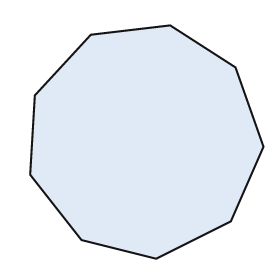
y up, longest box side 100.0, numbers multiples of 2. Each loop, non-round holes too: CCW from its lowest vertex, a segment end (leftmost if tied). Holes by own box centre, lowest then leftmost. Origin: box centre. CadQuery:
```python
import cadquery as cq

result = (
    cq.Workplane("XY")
    .moveTo(4.0, -50.0)
    .lineTo(36.0, -34.0)
    .lineTo(50.0, -2.0)
    .lineTo(38.0, 32.0)
    .lineTo(10.0, 50.0)
    .lineTo(-24.0, 46.0)
    .lineTo(-48.0, 20.0)
    .lineTo(-50.0, -14.0)
    .lineTo(-28.0, -42.0)
    .close()
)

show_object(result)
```